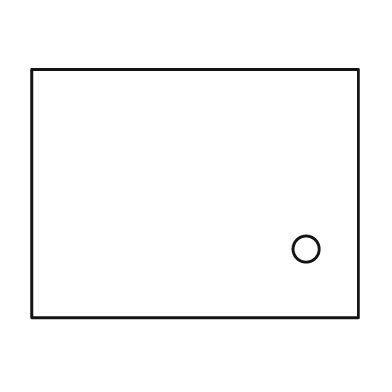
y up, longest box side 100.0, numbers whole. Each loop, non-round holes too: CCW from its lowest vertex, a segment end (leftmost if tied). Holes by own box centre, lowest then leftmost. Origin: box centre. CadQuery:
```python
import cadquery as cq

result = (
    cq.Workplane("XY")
    .moveTo(-50.0, -38.0)
    .lineTo(50.0, -38.0)
    .lineTo(50.0, 38.0)
    .lineTo(-50.0, 38.0)
    .close()
    .moveTo(34.0, -17.0)
    .circle(4.0)
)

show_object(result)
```